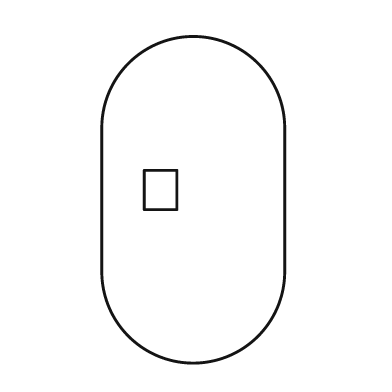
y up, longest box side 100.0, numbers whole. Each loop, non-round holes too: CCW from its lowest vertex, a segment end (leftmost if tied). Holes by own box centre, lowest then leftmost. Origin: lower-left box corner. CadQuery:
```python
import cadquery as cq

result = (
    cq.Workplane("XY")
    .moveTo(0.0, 28.0)
    .threePointArc((28.0, 0.0), (56.0, 28.0))
    .lineTo(56.0, 72.0)
    .threePointArc((28.0, 100.0), (0.0, 72.0))
    .close()
    .moveTo(13.0, 47.0)
    .lineTo(23.0, 47.0)
    .lineTo(23.0, 59.0)
    .lineTo(13.0, 59.0)
    .close()
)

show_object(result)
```